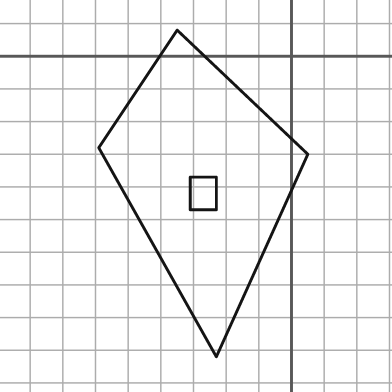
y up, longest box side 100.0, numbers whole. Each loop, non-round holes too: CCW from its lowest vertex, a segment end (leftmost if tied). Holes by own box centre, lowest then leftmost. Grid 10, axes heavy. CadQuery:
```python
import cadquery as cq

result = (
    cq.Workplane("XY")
    .moveTo(-23.0, -92.0)
    .lineTo(5.0, -30.0)
    .lineTo(-35.0, 8.0)
    .lineTo(-59.0, -28.0)
    .close()
    .moveTo(-31.0, -47.0)
    .lineTo(-23.0, -47.0)
    .lineTo(-23.0, -37.0)
    .lineTo(-31.0, -37.0)
    .close()
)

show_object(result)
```